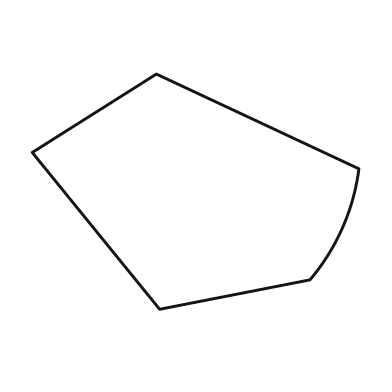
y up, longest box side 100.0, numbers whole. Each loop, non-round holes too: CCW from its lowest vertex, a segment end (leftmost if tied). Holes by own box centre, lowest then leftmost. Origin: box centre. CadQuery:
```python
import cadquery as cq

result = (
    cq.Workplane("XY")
    .moveTo(-11.0, -36.0)
    .lineTo(35.0, -27.0)
    .threePointArc((45.0, -11.0), (50.0, 7.0))
    .lineTo(-12.0, 36.0)
    .lineTo(-50.0, 12.0)
    .close()
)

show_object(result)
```